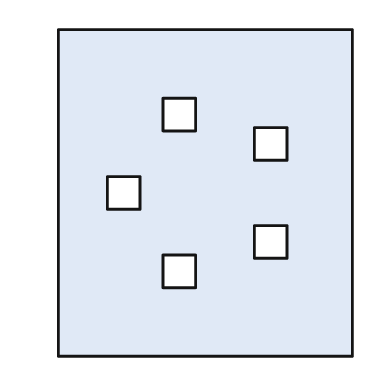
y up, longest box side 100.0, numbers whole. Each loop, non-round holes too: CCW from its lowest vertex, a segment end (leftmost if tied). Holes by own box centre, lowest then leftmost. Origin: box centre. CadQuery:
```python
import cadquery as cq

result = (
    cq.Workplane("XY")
    .moveTo(-45.0, -50.0)
    .lineTo(45.0, -50.0)
    .lineTo(45.0, 50.0)
    .lineTo(-45.0, 50.0)
    .close()
    .moveTo(-13.0, -29.0)
    .lineTo(-3.0, -29.0)
    .lineTo(-3.0, -19.0)
    .lineTo(-13.0, -19.0)
    .close()
    .moveTo(15.0, -20.0)
    .lineTo(25.0, -20.0)
    .lineTo(25.0, -10.0)
    .lineTo(15.0, -10.0)
    .close()
    .moveTo(-30.0, -5.0)
    .lineTo(-20.0, -5.0)
    .lineTo(-20.0, 5.0)
    .lineTo(-30.0, 5.0)
    .close()
    .moveTo(15.0, 10.0)
    .lineTo(25.0, 10.0)
    .lineTo(25.0, 20.0)
    .lineTo(15.0, 20.0)
    .close()
    .moveTo(-13.0, 19.0)
    .lineTo(-3.0, 19.0)
    .lineTo(-3.0, 29.0)
    .lineTo(-13.0, 29.0)
    .close()
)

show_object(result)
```